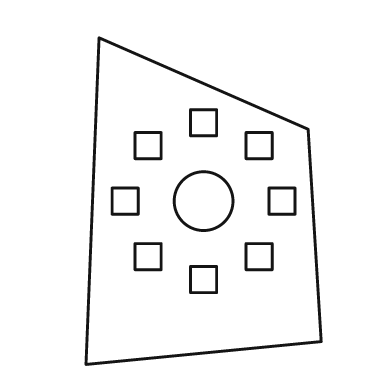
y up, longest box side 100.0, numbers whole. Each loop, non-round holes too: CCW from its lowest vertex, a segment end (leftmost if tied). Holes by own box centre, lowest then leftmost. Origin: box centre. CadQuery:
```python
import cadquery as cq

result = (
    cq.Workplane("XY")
    .moveTo(-36.0, -50.0)
    .lineTo(36.0, -43.0)
    .lineTo(32.0, 22.0)
    .lineTo(-32.0, 50.0)
    .close()
    .moveTo(-4.0, -28.0)
    .lineTo(4.0, -28.0)
    .lineTo(4.0, -20.0)
    .lineTo(-4.0, -20.0)
    .close()
    .moveTo(-21.0, -21.0)
    .lineTo(-13.0, -21.0)
    .lineTo(-13.0, -13.0)
    .lineTo(-21.0, -13.0)
    .close()
    .moveTo(13.0, -21.0)
    .lineTo(21.0, -21.0)
    .lineTo(21.0, -13.0)
    .lineTo(13.0, -13.0)
    .close()
    .moveTo(-28.0, -4.0)
    .lineTo(-20.0, -4.0)
    .lineTo(-20.0, 4.0)
    .lineTo(-28.0, 4.0)
    .close()
    .moveTo(0.0, 0.0)
    .circle(9.0)
    .moveTo(20.0, -4.0)
    .lineTo(28.0, -4.0)
    .lineTo(28.0, 4.0)
    .lineTo(20.0, 4.0)
    .close()
    .moveTo(-21.0, 13.0)
    .lineTo(-13.0, 13.0)
    .lineTo(-13.0, 21.0)
    .lineTo(-21.0, 21.0)
    .close()
    .moveTo(13.0, 13.0)
    .lineTo(21.0, 13.0)
    .lineTo(21.0, 21.0)
    .lineTo(13.0, 21.0)
    .close()
    .moveTo(-4.0, 20.0)
    .lineTo(4.0, 20.0)
    .lineTo(4.0, 28.0)
    .lineTo(-4.0, 28.0)
    .close()
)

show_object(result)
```